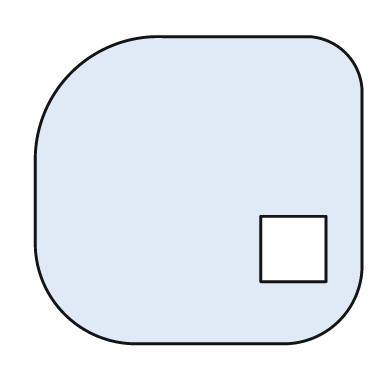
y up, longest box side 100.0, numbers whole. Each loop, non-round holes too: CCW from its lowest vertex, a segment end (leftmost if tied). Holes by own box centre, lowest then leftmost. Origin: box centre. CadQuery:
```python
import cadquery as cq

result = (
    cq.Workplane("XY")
    .moveTo(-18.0, -47.0)
    .lineTo(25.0, -47.0)
    .threePointArc((43.0, -40.0), (50.0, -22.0))
    .lineTo(50.0, 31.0)
    .threePointArc((45.0, 42.0), (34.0, 47.0))
    .lineTo(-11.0, 47.0)
    .threePointArc((-39.0, 36.0), (-50.0, 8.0))
    .lineTo(-50.0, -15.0)
    .threePointArc((-41.0, -38.0), (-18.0, -47.0))
    .close()
    .moveTo(19.0, -28.0)
    .lineTo(39.0, -28.0)
    .lineTo(39.0, -8.0)
    .lineTo(19.0, -8.0)
    .close()
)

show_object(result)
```